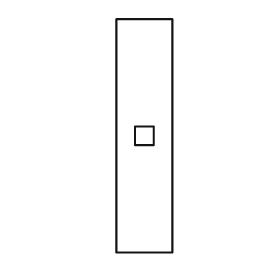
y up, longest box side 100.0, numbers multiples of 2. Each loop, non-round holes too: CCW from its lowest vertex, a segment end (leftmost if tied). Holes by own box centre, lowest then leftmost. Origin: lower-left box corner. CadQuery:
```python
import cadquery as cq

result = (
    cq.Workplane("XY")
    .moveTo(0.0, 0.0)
    .lineTo(24.0, 0.0)
    .lineTo(24.0, 100.0)
    .lineTo(0.0, 100.0)
    .close()
    .moveTo(8.0, 46.0)
    .lineTo(16.0, 46.0)
    .lineTo(16.0, 54.0)
    .lineTo(8.0, 54.0)
    .close()
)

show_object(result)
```